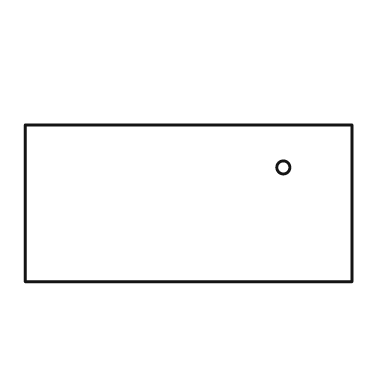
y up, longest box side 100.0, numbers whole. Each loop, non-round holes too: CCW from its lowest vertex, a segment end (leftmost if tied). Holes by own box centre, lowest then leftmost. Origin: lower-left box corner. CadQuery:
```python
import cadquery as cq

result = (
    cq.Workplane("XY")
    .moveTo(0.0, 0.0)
    .lineTo(100.0, 0.0)
    .lineTo(100.0, 48.0)
    .lineTo(0.0, 48.0)
    .close()
    .moveTo(79.0, 35.0)
    .circle(2.0)
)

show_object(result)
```